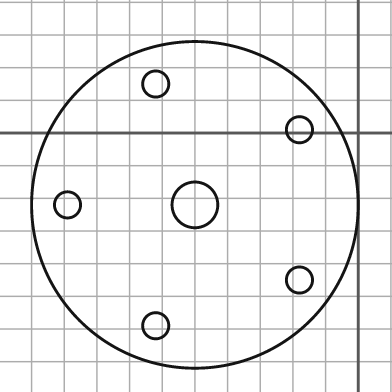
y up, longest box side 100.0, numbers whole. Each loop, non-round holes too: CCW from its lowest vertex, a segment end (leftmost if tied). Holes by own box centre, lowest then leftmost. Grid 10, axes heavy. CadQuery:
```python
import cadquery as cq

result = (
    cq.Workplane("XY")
    .moveTo(-50.0, -22.0)
    .circle(50.0)
    .moveTo(-62.0, -59.0)
    .circle(4.0)
    .moveTo(-18.0, -45.0)
    .circle(4.0)
    .moveTo(-89.0, -22.0)
    .circle(4.0)
    .moveTo(-50.0, -22.0)
    .circle(7.0)
    .moveTo(-18.0, 1.0)
    .circle(4.0)
    .moveTo(-62.0, 15.0)
    .circle(4.0)
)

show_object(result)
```